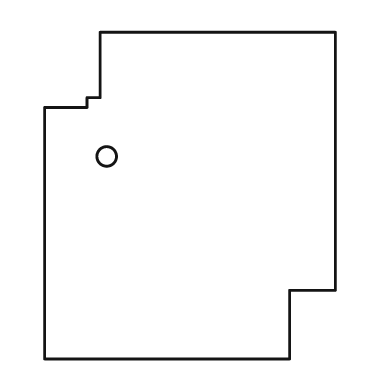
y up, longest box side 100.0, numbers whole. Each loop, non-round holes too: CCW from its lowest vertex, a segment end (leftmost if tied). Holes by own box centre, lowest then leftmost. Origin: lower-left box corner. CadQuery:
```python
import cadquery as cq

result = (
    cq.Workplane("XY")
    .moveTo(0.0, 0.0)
    .lineTo(75.0, 0.0)
    .lineTo(75.0, 21.0)
    .lineTo(89.0, 21.0)
    .lineTo(89.0, 100.0)
    .lineTo(17.0, 100.0)
    .lineTo(17.0, 80.0)
    .lineTo(13.0, 80.0)
    .lineTo(13.0, 77.0)
    .lineTo(0.0, 77.0)
    .close()
    .moveTo(19.0, 62.0)
    .circle(3.0)
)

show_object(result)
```